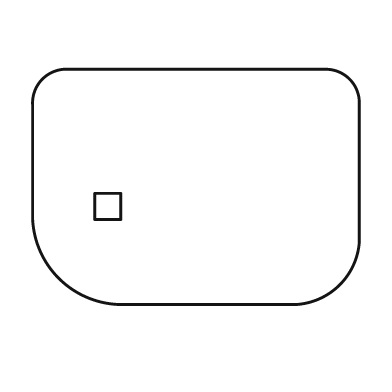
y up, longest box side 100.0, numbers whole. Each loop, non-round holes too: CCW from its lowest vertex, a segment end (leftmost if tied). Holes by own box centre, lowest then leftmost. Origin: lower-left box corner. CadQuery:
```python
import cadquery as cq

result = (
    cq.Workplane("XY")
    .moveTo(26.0, 0.0)
    .lineTo(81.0, 0.0)
    .threePointArc((94.0, 6.0), (100.0, 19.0))
    .lineTo(100.0, 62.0)
    .threePointArc((97.0, 69.0), (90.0, 72.0))
    .lineTo(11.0, 72.0)
    .threePointArc((3.0, 69.0), (0.0, 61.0))
    .lineTo(0.0, 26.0)
    .threePointArc((8.0, 8.0), (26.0, 0.0))
    .close()
    .moveTo(19.0, 26.0)
    .lineTo(27.0, 26.0)
    .lineTo(27.0, 34.0)
    .lineTo(19.0, 34.0)
    .close()
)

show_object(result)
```